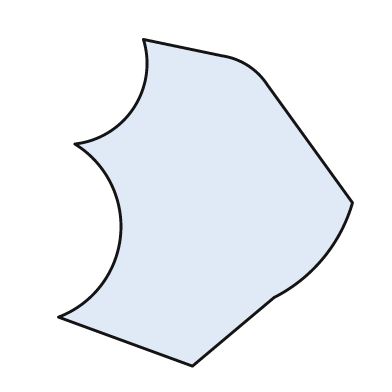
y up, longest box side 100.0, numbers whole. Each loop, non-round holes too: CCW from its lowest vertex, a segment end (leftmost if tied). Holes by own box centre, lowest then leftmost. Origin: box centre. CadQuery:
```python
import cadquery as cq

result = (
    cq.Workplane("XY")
    .moveTo(-4.0, -50.0)
    .lineTo(21.0, -29.0)
    .threePointArc((36.0, -17.0), (45.0, 0.0))
    .lineTo(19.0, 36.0)
    .threePointArc((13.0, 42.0), (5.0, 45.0))
    .lineTo(-19.0, 50.0)
    .threePointArc((-22.0, 29.0), (-40.0, 18.0))
    .threePointArc((-26.0, -10.0), (-45.0, -35.0))
    .close()
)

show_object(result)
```